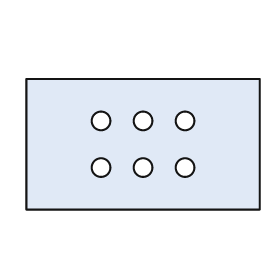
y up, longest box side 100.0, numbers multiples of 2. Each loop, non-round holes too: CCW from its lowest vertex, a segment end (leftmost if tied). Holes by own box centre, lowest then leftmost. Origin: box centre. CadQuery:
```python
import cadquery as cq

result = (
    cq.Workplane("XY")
    .moveTo(-50.0, -28.0)
    .lineTo(50.0, -28.0)
    .lineTo(50.0, 28.0)
    .lineTo(-50.0, 28.0)
    .close()
    .moveTo(-18.0, -10.0)
    .circle(4.0)
    .moveTo(0.0, -10.0)
    .circle(4.0)
    .moveTo(18.0, -10.0)
    .circle(4.0)
    .moveTo(-18.0, 10.0)
    .circle(4.0)
    .moveTo(0.0, 10.0)
    .circle(4.0)
    .moveTo(18.0, 10.0)
    .circle(4.0)
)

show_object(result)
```